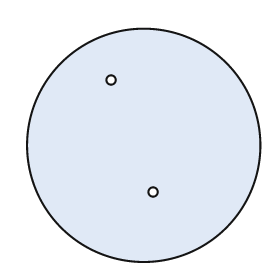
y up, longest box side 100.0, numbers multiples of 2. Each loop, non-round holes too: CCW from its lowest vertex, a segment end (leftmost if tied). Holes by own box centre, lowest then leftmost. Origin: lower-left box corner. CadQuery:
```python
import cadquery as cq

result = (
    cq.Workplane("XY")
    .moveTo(50.0, 50.0)
    .circle(50.0)
    .moveTo(54.0, 30.0)
    .circle(2.0)
    .moveTo(36.0, 78.0)
    .circle(2.0)
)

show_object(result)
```